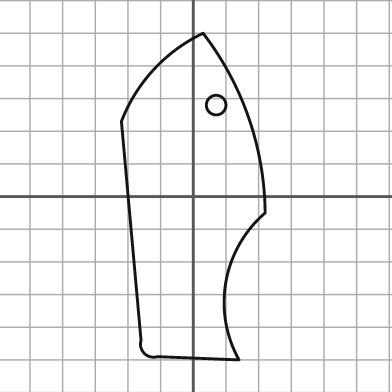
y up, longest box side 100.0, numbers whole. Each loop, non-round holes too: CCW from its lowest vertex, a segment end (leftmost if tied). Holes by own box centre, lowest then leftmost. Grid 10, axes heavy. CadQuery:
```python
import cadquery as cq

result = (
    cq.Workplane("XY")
    .moveTo(14.0, -50.0)
    .threePointArc((10.0, -26.0), (22.0, -5.0))
    .threePointArc((17.0, 24.0), (3.0, 50.0))
    .threePointArc((-12.0, 39.0), (-22.0, 23.0))
    .lineTo(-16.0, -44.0)
    .threePointArc((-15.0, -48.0), (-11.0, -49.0))
    .close()
    .moveTo(7.0, 28.0)
    .circle(3.0)
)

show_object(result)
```